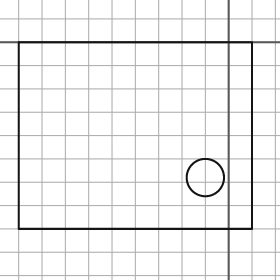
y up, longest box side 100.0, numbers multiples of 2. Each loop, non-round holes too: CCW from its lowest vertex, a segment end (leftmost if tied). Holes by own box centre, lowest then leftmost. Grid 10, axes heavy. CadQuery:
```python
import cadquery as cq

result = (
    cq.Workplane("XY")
    .moveTo(-90.0, -80.0)
    .lineTo(10.0, -80.0)
    .lineTo(10.0, 0.0)
    .lineTo(-90.0, 0.0)
    .close()
    .moveTo(-10.0, -58.0)
    .circle(8.0)
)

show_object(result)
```